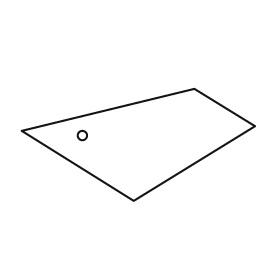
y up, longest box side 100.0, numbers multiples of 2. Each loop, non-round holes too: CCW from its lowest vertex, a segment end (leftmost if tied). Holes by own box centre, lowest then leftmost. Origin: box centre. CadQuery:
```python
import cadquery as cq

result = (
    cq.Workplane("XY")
    .moveTo(-2.0, -24.0)
    .lineTo(50.0, 8.0)
    .lineTo(24.0, 24.0)
    .lineTo(-50.0, 6.0)
    .close()
    .moveTo(-24.0, 4.0)
    .circle(2.0)
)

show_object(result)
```